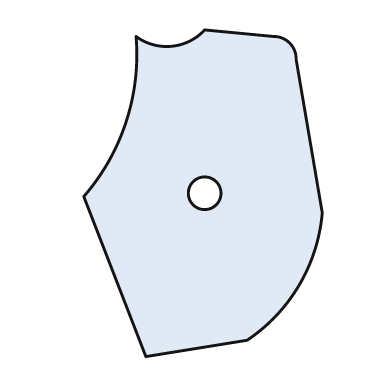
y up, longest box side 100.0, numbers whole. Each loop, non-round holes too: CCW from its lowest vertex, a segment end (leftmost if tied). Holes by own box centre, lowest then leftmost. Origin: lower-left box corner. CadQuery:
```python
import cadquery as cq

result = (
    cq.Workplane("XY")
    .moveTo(19.0, 0.0)
    .lineTo(50.0, 5.0)
    .threePointArc((66.0, 22.0), (73.0, 44.0))
    .lineTo(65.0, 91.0)
    .threePointArc((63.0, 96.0), (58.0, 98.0))
    .lineTo(37.0, 100.0)
    .threePointArc((27.0, 95.0), (16.0, 98.0))
    .threePointArc((13.0, 72.0), (0.0, 49.0))
    .close()
    .moveTo(37.0, 50.0)
    .circle(5.0)
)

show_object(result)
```